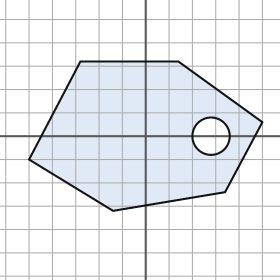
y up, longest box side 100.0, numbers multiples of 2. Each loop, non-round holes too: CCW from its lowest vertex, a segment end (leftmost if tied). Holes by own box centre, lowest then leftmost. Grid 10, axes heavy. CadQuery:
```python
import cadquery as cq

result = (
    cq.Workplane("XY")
    .moveTo(-14.0, -32.0)
    .lineTo(34.0, -24.0)
    .lineTo(50.0, 6.0)
    .lineTo(14.0, 32.0)
    .lineTo(-28.0, 32.0)
    .lineTo(-50.0, -10.0)
    .close()
    .moveTo(28.0, 0.0)
    .circle(8.0)
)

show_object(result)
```